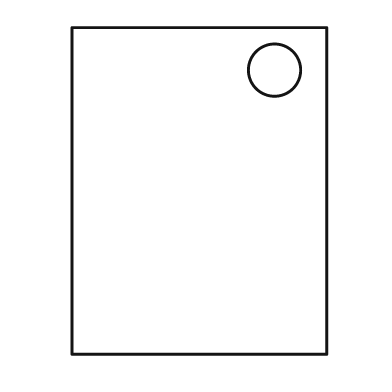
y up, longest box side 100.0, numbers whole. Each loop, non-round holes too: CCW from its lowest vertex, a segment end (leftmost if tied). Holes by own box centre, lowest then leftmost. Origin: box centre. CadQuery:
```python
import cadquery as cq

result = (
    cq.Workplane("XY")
    .moveTo(-39.0, -50.0)
    .lineTo(39.0, -50.0)
    .lineTo(39.0, 50.0)
    .lineTo(-39.0, 50.0)
    .close()
    .moveTo(23.0, 37.0)
    .circle(8.0)
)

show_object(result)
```